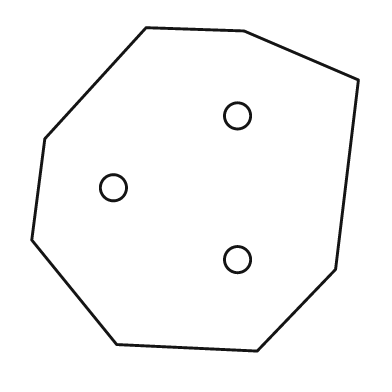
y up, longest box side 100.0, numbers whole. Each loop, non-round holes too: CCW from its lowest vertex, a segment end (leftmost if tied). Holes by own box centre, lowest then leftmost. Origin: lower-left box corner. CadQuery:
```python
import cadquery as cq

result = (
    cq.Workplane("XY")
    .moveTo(69.0, 0.0)
    .lineTo(93.0, 25.0)
    .lineTo(100.0, 83.0)
    .lineTo(65.0, 98.0)
    .lineTo(35.0, 99.0)
    .lineTo(4.0, 65.0)
    .lineTo(0.0, 34.0)
    .lineTo(26.0, 2.0)
    .close()
    .moveTo(63.0, 28.0)
    .circle(4.0)
    .moveTo(25.0, 50.0)
    .circle(4.0)
    .moveTo(63.0, 72.0)
    .circle(4.0)
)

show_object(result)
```